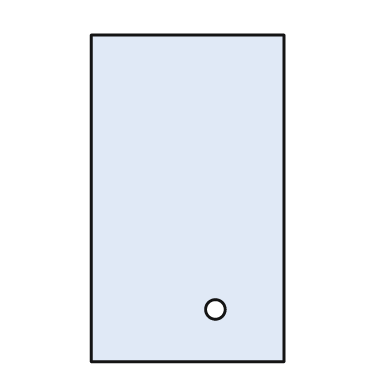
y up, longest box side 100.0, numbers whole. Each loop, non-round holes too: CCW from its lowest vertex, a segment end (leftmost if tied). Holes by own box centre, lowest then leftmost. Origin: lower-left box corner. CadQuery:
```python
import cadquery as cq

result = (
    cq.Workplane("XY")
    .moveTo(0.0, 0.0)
    .lineTo(59.0, 0.0)
    .lineTo(59.0, 100.0)
    .lineTo(0.0, 100.0)
    .close()
    .moveTo(38.0, 16.0)
    .circle(3.0)
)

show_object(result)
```